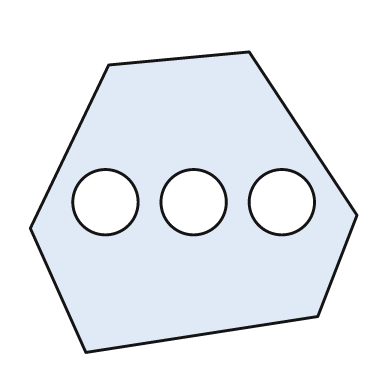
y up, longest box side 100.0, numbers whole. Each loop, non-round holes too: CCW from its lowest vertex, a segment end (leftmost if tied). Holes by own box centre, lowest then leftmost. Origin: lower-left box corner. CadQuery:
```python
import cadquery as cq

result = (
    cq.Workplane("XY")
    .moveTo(17.0, 0.0)
    .lineTo(88.0, 11.0)
    .lineTo(100.0, 42.0)
    .lineTo(67.0, 92.0)
    .lineTo(24.0, 88.0)
    .lineTo(0.0, 38.0)
    .close()
    .moveTo(23.0, 46.0)
    .circle(10.0)
    .moveTo(50.0, 46.0)
    .circle(10.0)
    .moveTo(77.0, 46.0)
    .circle(10.0)
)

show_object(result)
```